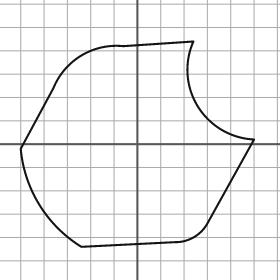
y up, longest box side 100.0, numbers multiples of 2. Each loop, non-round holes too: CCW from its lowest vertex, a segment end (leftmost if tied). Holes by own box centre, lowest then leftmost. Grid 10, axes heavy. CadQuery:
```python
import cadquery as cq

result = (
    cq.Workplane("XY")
    .moveTo(-24.0, -44.0)
    .lineTo(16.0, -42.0)
    .threePointArc((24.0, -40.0), (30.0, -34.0))
    .lineTo(50.0, 2.0)
    .threePointArc((26.0, 16.0), (24.0, 44.0))
    .lineTo(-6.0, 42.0)
    .threePointArc((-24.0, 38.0), (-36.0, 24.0))
    .lineTo(-50.0, -2.0)
    .threePointArc((-42.0, -26.0), (-24.0, -44.0))
    .close()
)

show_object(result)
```